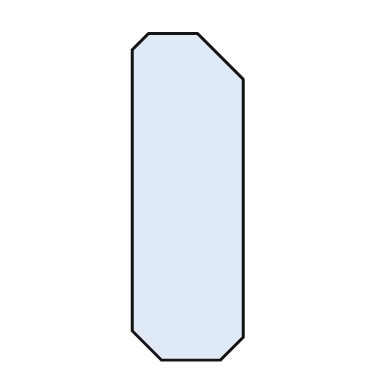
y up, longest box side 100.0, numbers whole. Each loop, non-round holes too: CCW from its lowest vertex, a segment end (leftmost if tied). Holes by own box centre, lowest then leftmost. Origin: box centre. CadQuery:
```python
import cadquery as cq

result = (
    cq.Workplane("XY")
    .moveTo(-8.0, -50.0)
    .lineTo(10.0, -50.0)
    .lineTo(17.0, -43.0)
    .lineTo(17.0, 36.0)
    .lineTo(3.0, 50.0)
    .lineTo(-12.0, 50.0)
    .lineTo(-17.0, 45.0)
    .lineTo(-17.0, -41.0)
    .close()
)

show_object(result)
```